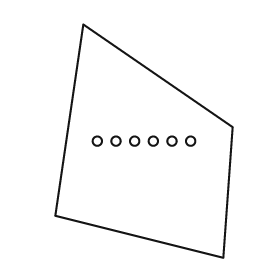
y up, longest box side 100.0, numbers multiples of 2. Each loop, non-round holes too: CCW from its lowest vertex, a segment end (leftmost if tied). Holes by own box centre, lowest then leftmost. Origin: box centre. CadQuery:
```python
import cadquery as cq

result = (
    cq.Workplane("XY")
    .moveTo(34.0, -50.0)
    .lineTo(38.0, 6.0)
    .lineTo(-26.0, 50.0)
    .lineTo(-38.0, -32.0)
    .close()
    .moveTo(-20.0, 0.0)
    .circle(2.0)
    .moveTo(-12.0, 0.0)
    .circle(2.0)
    .moveTo(-4.0, 0.0)
    .circle(2.0)
    .moveTo(4.0, 0.0)
    .circle(2.0)
    .moveTo(12.0, 0.0)
    .circle(2.0)
    .moveTo(20.0, 0.0)
    .circle(2.0)
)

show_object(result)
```